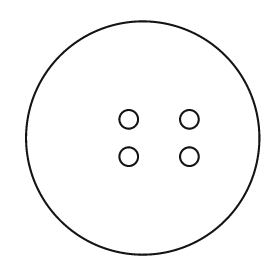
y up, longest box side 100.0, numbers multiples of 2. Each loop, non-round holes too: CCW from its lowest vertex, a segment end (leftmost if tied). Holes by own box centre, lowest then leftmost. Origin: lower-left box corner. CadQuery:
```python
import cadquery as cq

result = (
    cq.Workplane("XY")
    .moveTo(50.0, 50.0)
    .circle(50.0)
    .moveTo(44.0, 42.0)
    .circle(4.0)
    .moveTo(70.0, 42.0)
    .circle(4.0)
    .moveTo(44.0, 58.0)
    .circle(4.0)
    .moveTo(70.0, 58.0)
    .circle(4.0)
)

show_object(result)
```